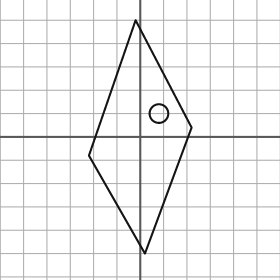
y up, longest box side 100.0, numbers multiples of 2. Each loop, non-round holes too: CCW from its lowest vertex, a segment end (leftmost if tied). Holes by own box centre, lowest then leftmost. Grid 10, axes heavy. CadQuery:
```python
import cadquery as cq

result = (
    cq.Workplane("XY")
    .moveTo(2.0, -50.0)
    .lineTo(22.0, 4.0)
    .lineTo(-2.0, 50.0)
    .lineTo(-22.0, -8.0)
    .close()
    .moveTo(8.0, 10.0)
    .circle(4.0)
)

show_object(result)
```